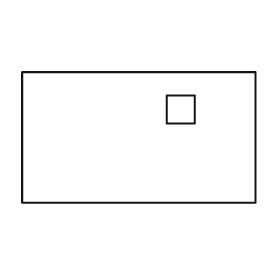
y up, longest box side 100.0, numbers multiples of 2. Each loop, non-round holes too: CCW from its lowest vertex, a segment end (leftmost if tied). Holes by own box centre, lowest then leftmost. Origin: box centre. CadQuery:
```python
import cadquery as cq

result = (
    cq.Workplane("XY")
    .moveTo(-50.0, -28.0)
    .lineTo(50.0, -28.0)
    .lineTo(50.0, 28.0)
    .lineTo(-50.0, 28.0)
    .close()
    .moveTo(12.0, 6.0)
    .lineTo(24.0, 6.0)
    .lineTo(24.0, 18.0)
    .lineTo(12.0, 18.0)
    .close()
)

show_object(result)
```